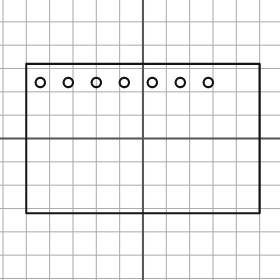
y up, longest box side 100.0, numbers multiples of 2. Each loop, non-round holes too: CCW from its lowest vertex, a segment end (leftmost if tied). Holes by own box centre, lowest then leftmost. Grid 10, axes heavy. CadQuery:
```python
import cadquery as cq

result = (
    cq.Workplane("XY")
    .moveTo(-50.0, -32.0)
    .lineTo(50.0, -32.0)
    .lineTo(50.0, 32.0)
    .lineTo(-50.0, 32.0)
    .close()
    .moveTo(-44.0, 24.0)
    .circle(2.0)
    .moveTo(-32.0, 24.0)
    .circle(2.0)
    .moveTo(-20.0, 24.0)
    .circle(2.0)
    .moveTo(-8.0, 24.0)
    .circle(2.0)
    .moveTo(4.0, 24.0)
    .circle(2.0)
    .moveTo(16.0, 24.0)
    .circle(2.0)
    .moveTo(28.0, 24.0)
    .circle(2.0)
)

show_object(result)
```